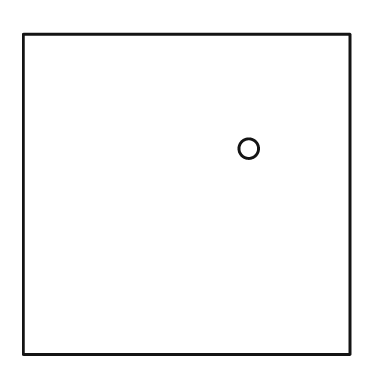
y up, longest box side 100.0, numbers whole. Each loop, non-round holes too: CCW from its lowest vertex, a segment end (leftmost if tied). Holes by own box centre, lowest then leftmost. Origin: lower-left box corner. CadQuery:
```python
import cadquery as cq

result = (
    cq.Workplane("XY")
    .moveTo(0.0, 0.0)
    .lineTo(100.0, 0.0)
    .lineTo(100.0, 98.0)
    .lineTo(0.0, 98.0)
    .close()
    .moveTo(69.0, 63.0)
    .circle(3.0)
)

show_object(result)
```